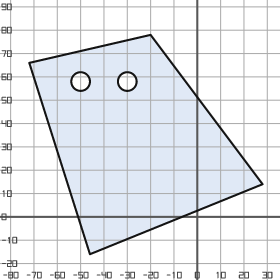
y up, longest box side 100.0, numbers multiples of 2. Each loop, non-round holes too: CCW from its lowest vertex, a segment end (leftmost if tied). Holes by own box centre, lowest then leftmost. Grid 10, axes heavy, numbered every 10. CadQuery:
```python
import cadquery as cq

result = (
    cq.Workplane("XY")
    .moveTo(-46.0, -16.0)
    .lineTo(28.0, 14.0)
    .lineTo(-20.0, 78.0)
    .lineTo(-72.0, 66.0)
    .close()
    .moveTo(-50.0, 58.0)
    .circle(4.0)
    .moveTo(-30.0, 58.0)
    .circle(4.0)
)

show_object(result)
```